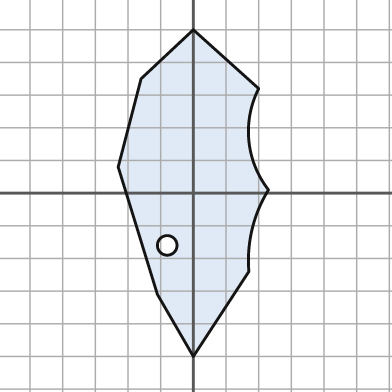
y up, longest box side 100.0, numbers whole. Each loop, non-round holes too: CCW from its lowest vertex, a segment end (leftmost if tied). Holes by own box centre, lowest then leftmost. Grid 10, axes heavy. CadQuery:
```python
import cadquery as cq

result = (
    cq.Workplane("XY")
    .moveTo(0.0, -50.0)
    .lineTo(17.0, -24.0)
    .threePointArc((18.0, -11.0), (23.0, 1.0))
    .threePointArc((17.0, 16.0), (20.0, 32.0))
    .lineTo(0.0, 50.0)
    .lineTo(-16.0, 35.0)
    .lineTo(-23.0, 8.0)
    .lineTo(-11.0, -31.0)
    .close()
    .moveTo(-8.0, -16.0)
    .circle(3.0)
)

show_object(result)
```